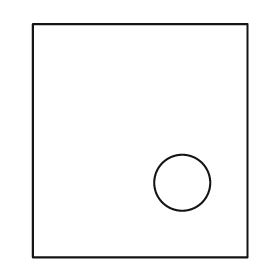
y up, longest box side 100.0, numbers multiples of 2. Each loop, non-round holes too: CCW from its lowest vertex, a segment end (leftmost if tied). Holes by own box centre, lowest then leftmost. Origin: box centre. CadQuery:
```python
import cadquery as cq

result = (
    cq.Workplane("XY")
    .moveTo(-46.0, -50.0)
    .lineTo(46.0, -50.0)
    .lineTo(46.0, 50.0)
    .lineTo(-46.0, 50.0)
    .close()
    .moveTo(18.0, -18.0)
    .circle(12.0)
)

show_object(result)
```